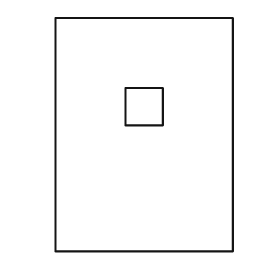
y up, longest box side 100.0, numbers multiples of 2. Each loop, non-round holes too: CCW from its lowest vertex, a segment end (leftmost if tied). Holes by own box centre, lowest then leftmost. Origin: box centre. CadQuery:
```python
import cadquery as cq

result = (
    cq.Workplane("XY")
    .moveTo(-38.0, -50.0)
    .lineTo(38.0, -50.0)
    .lineTo(38.0, 50.0)
    .lineTo(-38.0, 50.0)
    .close()
    .moveTo(-8.0, 4.0)
    .lineTo(8.0, 4.0)
    .lineTo(8.0, 20.0)
    .lineTo(-8.0, 20.0)
    .close()
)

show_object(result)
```